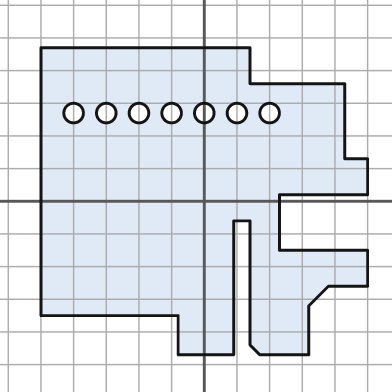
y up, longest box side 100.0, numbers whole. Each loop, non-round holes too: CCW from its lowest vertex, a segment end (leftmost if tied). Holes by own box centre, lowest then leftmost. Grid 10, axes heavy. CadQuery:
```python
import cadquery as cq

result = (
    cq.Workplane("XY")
    .moveTo(-8.0, -47.0)
    .lineTo(9.0, -47.0)
    .lineTo(9.0, -6.0)
    .lineTo(14.0, -6.0)
    .lineTo(14.0, -44.0)
    .lineTo(17.0, -47.0)
    .lineTo(32.0, -47.0)
    .lineTo(32.0, -32.0)
    .lineTo(38.0, -26.0)
    .lineTo(50.0, -26.0)
    .lineTo(50.0, -15.0)
    .lineTo(23.0, -15.0)
    .lineTo(23.0, 2.0)
    .lineTo(50.0, 2.0)
    .lineTo(50.0, 13.0)
    .lineTo(43.0, 13.0)
    .lineTo(43.0, 36.0)
    .lineTo(14.0, 36.0)
    .lineTo(14.0, 47.0)
    .lineTo(-50.0, 47.0)
    .lineTo(-50.0, -35.0)
    .lineTo(-8.0, -35.0)
    .close()
    .moveTo(-40.0, 27.0)
    .circle(3.0)
    .moveTo(-30.0, 27.0)
    .circle(3.0)
    .moveTo(-20.0, 27.0)
    .circle(3.0)
    .moveTo(-10.0, 27.0)
    .circle(3.0)
    .moveTo(0.0, 27.0)
    .circle(3.0)
    .moveTo(10.0, 27.0)
    .circle(3.0)
    .moveTo(20.0, 27.0)
    .circle(3.0)
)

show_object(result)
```